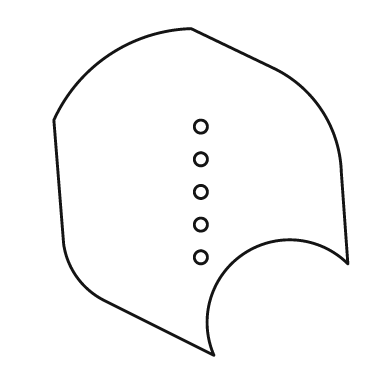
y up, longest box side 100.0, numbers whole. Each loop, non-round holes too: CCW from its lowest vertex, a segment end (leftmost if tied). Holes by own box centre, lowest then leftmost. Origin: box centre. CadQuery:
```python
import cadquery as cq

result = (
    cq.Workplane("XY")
    .moveTo(4.0, -50.0)
    .threePointArc((13.0, -19.0), (45.0, -22.0))
    .lineTo(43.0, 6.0)
    .threePointArc((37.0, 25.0), (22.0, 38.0))
    .lineTo(-3.0, 50.0)
    .threePointArc((-28.0, 42.0), (-45.0, 22.0))
    .lineTo(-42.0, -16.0)
    .threePointArc((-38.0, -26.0), (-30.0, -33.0))
    .close()
    .moveTo(0.0, -20.0)
    .circle(2.0)
    .moveTo(0.0, -10.0)
    .circle(2.0)
    .moveTo(0.0, 0.0)
    .circle(2.0)
    .moveTo(0.0, 10.0)
    .circle(2.0)
    .moveTo(0.0, 20.0)
    .circle(2.0)
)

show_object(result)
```